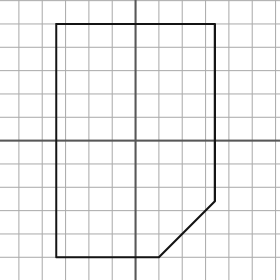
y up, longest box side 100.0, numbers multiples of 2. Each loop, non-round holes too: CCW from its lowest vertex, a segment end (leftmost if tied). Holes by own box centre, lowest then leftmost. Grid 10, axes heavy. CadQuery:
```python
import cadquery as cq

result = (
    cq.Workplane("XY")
    .moveTo(-34.0, -50.0)
    .lineTo(10.0, -50.0)
    .lineTo(34.0, -26.0)
    .lineTo(34.0, 50.0)
    .lineTo(-34.0, 50.0)
    .close()
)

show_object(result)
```